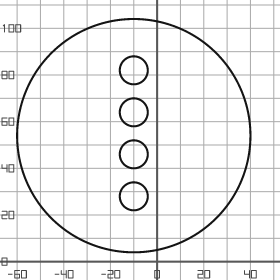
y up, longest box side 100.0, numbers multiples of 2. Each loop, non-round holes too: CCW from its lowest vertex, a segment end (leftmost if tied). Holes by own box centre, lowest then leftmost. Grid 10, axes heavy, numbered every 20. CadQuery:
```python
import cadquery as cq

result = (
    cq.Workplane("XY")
    .moveTo(-10.0, 54.0)
    .circle(50.0)
    .moveTo(-10.0, 28.0)
    .circle(6.0)
    .moveTo(-10.0, 46.0)
    .circle(6.0)
    .moveTo(-10.0, 64.0)
    .circle(6.0)
    .moveTo(-10.0, 82.0)
    .circle(6.0)
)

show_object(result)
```